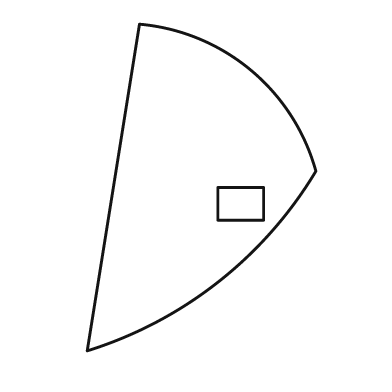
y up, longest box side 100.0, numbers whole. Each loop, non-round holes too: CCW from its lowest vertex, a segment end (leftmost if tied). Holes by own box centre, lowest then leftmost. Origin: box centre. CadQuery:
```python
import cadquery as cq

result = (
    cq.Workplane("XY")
    .moveTo(-35.0, -50.0)
    .threePointArc((5.0, -29.0), (35.0, 5.0))
    .threePointArc((15.0, 36.0), (-19.0, 50.0))
    .close()
    .moveTo(5.0, -10.0)
    .lineTo(19.0, -10.0)
    .lineTo(19.0, 0.0)
    .lineTo(5.0, 0.0)
    .close()
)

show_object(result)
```